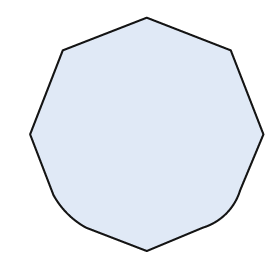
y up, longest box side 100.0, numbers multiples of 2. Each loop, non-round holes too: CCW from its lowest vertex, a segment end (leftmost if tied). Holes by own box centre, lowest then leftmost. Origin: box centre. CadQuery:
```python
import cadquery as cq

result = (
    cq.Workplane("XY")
    .moveTo(0.0, -50.0)
    .lineTo(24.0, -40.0)
    .threePointArc((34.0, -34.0), (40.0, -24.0))
    .lineTo(50.0, 0.0)
    .lineTo(36.0, 36.0)
    .lineTo(0.0, 50.0)
    .lineTo(-36.0, 36.0)
    .lineTo(-50.0, 0.0)
    .lineTo(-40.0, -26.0)
    .threePointArc((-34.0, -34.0), (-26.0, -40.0))
    .close()
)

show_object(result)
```